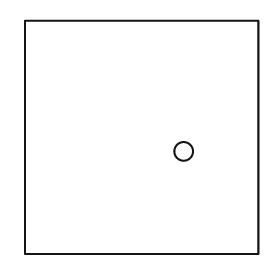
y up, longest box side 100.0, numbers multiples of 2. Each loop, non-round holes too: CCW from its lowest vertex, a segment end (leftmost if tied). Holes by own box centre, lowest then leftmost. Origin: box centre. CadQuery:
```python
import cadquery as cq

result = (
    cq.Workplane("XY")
    .moveTo(-50.0, -50.0)
    .lineTo(50.0, -50.0)
    .lineTo(50.0, 50.0)
    .lineTo(-50.0, 50.0)
    .close()
    .moveTo(18.0, -6.0)
    .circle(4.0)
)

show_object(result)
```